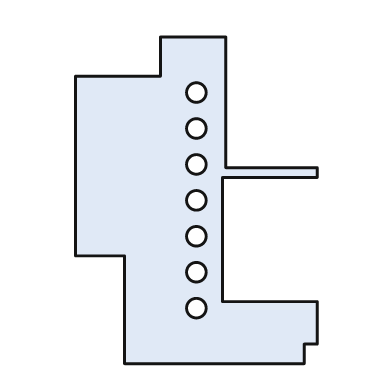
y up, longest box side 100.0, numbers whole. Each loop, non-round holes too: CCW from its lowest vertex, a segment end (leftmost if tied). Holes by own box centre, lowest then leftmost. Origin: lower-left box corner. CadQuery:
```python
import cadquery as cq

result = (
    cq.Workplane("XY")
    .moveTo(15.0, 0.0)
    .lineTo(70.0, 0.0)
    .lineTo(70.0, 6.0)
    .lineTo(74.0, 6.0)
    .lineTo(74.0, 19.0)
    .lineTo(45.0, 19.0)
    .lineTo(45.0, 57.0)
    .lineTo(74.0, 57.0)
    .lineTo(74.0, 60.0)
    .lineTo(46.0, 60.0)
    .lineTo(46.0, 100.0)
    .lineTo(26.0, 100.0)
    .lineTo(26.0, 88.0)
    .lineTo(0.0, 88.0)
    .lineTo(0.0, 33.0)
    .lineTo(15.0, 33.0)
    .close()
    .moveTo(37.0, 17.0)
    .circle(3.0)
    .moveTo(37.0, 28.0)
    .circle(3.0)
    .moveTo(37.0, 39.0)
    .circle(3.0)
    .moveTo(37.0, 50.0)
    .circle(3.0)
    .moveTo(37.0, 61.0)
    .circle(3.0)
    .moveTo(37.0, 72.0)
    .circle(3.0)
    .moveTo(37.0, 83.0)
    .circle(3.0)
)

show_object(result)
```